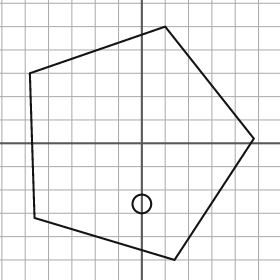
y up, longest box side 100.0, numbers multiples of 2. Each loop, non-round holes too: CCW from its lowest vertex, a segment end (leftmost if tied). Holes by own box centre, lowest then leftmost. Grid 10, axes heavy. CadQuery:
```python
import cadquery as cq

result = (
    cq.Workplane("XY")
    .moveTo(14.0, -50.0)
    .lineTo(48.0, 2.0)
    .lineTo(10.0, 50.0)
    .lineTo(-48.0, 30.0)
    .lineTo(-46.0, -32.0)
    .close()
    .moveTo(0.0, -26.0)
    .circle(4.0)
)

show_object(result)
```